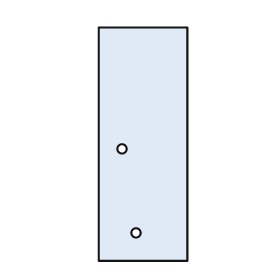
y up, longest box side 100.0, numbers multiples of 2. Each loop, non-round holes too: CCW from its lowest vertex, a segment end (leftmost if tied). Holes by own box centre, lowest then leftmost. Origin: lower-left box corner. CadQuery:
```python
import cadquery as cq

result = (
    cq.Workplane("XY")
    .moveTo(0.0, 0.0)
    .lineTo(38.0, 0.0)
    .lineTo(38.0, 100.0)
    .lineTo(0.0, 100.0)
    .close()
    .moveTo(16.0, 12.0)
    .circle(2.0)
    .moveTo(10.0, 48.0)
    .circle(2.0)
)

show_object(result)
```